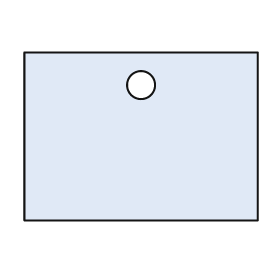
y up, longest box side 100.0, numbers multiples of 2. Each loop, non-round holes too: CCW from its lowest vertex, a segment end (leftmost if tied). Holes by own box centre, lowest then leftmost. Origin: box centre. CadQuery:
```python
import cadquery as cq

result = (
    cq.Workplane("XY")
    .moveTo(-50.0, -36.0)
    .lineTo(50.0, -36.0)
    .lineTo(50.0, 36.0)
    .lineTo(-50.0, 36.0)
    .close()
    .moveTo(0.0, 22.0)
    .circle(6.0)
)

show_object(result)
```